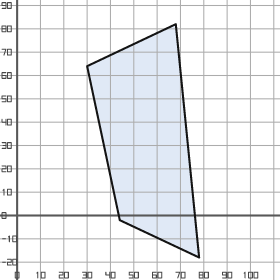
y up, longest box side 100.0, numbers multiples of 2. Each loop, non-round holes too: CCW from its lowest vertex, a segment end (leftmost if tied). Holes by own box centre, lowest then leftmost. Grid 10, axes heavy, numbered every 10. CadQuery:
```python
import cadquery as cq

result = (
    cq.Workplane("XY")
    .moveTo(78.0, -18.0)
    .lineTo(68.0, 82.0)
    .lineTo(30.0, 64.0)
    .lineTo(44.0, -2.0)
    .close()
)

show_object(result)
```